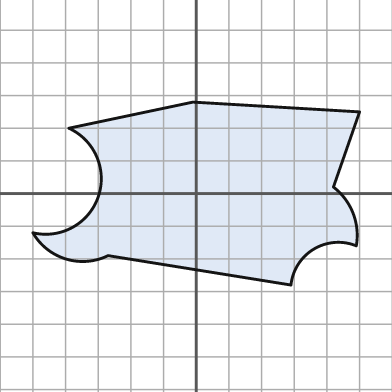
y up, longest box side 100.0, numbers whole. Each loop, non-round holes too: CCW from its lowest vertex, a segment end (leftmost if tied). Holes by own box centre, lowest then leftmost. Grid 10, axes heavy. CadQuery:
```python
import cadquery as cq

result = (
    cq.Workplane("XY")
    .moveTo(29.0, -28.0)
    .threePointArc((36.0, -17.0), (49.0, -16.0))
    .threePointArc((48.0, -6.0), (42.0, 2.0))
    .lineTo(50.0, 25.0)
    .lineTo(-1.0, 28.0)
    .lineTo(-39.0, 20.0)
    .threePointArc((-30.0, -1.0), (-50.0, -12.0))
    .threePointArc((-40.0, -20.0), (-27.0, -19.0))
    .close()
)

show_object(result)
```